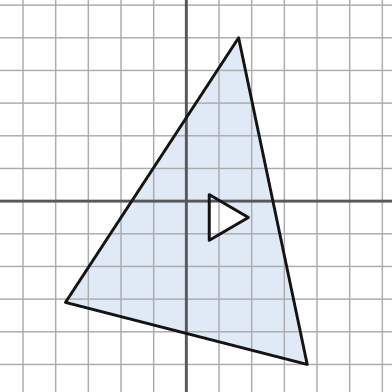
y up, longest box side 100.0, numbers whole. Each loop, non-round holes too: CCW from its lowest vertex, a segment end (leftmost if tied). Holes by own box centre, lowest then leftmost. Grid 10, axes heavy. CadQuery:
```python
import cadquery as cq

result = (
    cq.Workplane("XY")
    .moveTo(37.0, -50.0)
    .lineTo(16.0, 50.0)
    .lineTo(-37.0, -31.0)
    .close()
    .moveTo(7.0, -12.0)
    .lineTo(19.0, -5.0)
    .lineTo(7.0, 2.0)
    .close()
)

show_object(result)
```